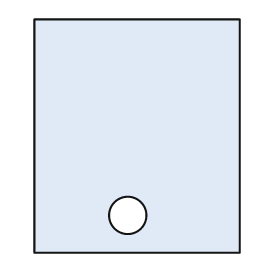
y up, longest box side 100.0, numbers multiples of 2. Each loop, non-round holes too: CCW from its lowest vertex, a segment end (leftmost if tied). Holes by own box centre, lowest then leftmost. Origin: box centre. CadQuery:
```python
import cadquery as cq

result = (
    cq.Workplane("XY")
    .moveTo(-44.0, -50.0)
    .lineTo(44.0, -50.0)
    .lineTo(44.0, 50.0)
    .lineTo(-44.0, 50.0)
    .close()
    .moveTo(-4.0, -34.0)
    .circle(8.0)
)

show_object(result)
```